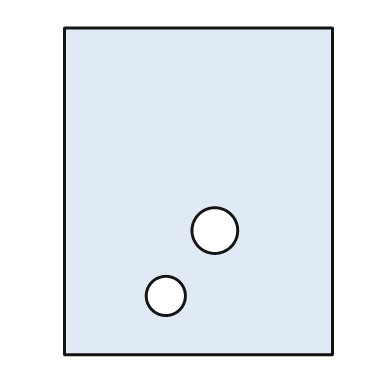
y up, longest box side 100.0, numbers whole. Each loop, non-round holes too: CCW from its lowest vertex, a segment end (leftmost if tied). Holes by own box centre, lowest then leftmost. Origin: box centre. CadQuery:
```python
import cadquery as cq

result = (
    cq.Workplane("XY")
    .moveTo(-41.0, -50.0)
    .lineTo(41.0, -50.0)
    .lineTo(41.0, 50.0)
    .lineTo(-41.0, 50.0)
    .close()
    .moveTo(-10.0, -32.0)
    .circle(6.0)
    .moveTo(5.0, -12.0)
    .circle(7.0)
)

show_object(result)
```